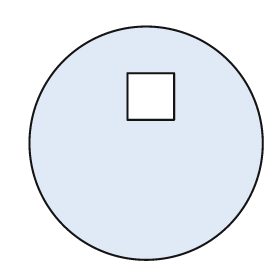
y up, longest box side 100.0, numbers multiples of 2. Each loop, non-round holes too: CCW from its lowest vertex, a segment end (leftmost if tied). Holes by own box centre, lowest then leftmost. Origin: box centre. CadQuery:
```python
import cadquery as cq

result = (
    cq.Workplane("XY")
    .moveTo(0.0, 0.0)
    .circle(50.0)
    .moveTo(-8.0, 10.0)
    .lineTo(12.0, 10.0)
    .lineTo(12.0, 30.0)
    .lineTo(-8.0, 30.0)
    .close()
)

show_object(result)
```